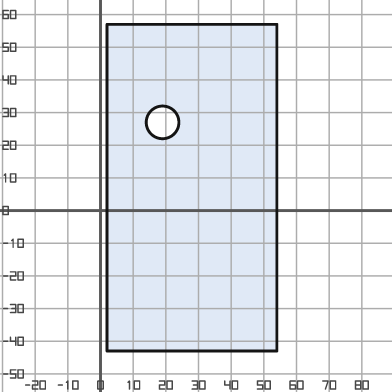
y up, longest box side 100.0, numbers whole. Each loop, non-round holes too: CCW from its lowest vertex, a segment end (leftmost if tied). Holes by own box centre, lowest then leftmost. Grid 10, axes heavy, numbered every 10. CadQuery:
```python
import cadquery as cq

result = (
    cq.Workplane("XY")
    .moveTo(2.0, -43.0)
    .lineTo(54.0, -43.0)
    .lineTo(54.0, 57.0)
    .lineTo(2.0, 57.0)
    .close()
    .moveTo(19.0, 27.0)
    .circle(5.0)
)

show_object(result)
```